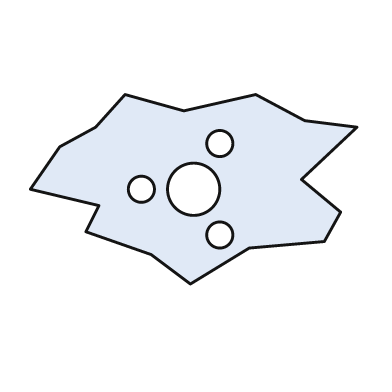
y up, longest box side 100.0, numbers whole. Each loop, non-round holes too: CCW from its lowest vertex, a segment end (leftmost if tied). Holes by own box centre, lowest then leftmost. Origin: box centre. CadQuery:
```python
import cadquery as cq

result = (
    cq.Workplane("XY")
    .moveTo(-1.0, -29.0)
    .lineTo(17.0, -18.0)
    .lineTo(40.0, -16.0)
    .lineTo(45.0, -7.0)
    .lineTo(33.0, 3.0)
    .lineTo(50.0, 19.0)
    .lineTo(34.0, 21.0)
    .lineTo(19.0, 29.0)
    .lineTo(-3.0, 24.0)
    .lineTo(-21.0, 29.0)
    .lineTo(-30.0, 19.0)
    .lineTo(-41.0, 13.0)
    .lineTo(-50.0, 0.0)
    .lineTo(-29.0, -5.0)
    .lineTo(-33.0, -13.0)
    .lineTo(-13.0, -20.0)
    .close()
    .moveTo(8.0, -14.0)
    .circle(4.0)
    .moveTo(-16.0, 0.0)
    .circle(4.0)
    .moveTo(0.0, 0.0)
    .circle(8.0)
    .moveTo(8.0, 14.0)
    .circle(4.0)
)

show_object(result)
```